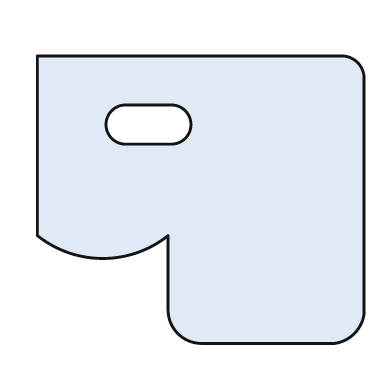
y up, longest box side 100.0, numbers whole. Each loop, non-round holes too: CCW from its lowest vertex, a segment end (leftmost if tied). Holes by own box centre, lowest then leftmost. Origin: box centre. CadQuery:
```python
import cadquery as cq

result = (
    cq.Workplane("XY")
    .moveTo(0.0, -44.0)
    .lineTo(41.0, -44.0)
    .threePointArc((47.0, -41.0), (50.0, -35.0))
    .lineTo(50.0, 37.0)
    .threePointArc((48.0, 42.0), (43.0, 44.0))
    .lineTo(-50.0, 44.0)
    .lineTo(-50.0, -11.0)
    .threePointArc((-30.0, -18.0), (-10.0, -11.0))
    .lineTo(-10.0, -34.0)
    .threePointArc((-7.0, -41.0), (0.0, -44.0))
    .close()
    .moveTo(-23.0, 17.0)
    .lineTo(-9.0, 17.0)
    .threePointArc((-3.0, 23.0), (-9.0, 29.0))
    .lineTo(-23.0, 29.0)
    .threePointArc((-29.0, 23.0), (-23.0, 17.0))
    .close()
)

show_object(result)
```